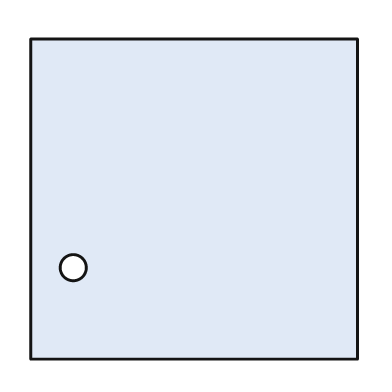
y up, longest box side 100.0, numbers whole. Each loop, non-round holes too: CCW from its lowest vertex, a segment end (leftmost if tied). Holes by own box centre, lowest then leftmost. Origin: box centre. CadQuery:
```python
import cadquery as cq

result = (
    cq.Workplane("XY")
    .moveTo(-50.0, -49.0)
    .lineTo(50.0, -49.0)
    .lineTo(50.0, 49.0)
    .lineTo(-50.0, 49.0)
    .close()
    .moveTo(-37.0, -21.0)
    .circle(4.0)
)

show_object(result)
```